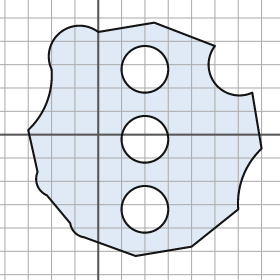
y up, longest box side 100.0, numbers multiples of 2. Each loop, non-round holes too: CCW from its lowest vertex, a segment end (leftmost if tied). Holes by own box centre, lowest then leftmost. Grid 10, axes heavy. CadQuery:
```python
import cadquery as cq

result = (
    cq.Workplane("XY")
    .moveTo(16.0, -52.0)
    .lineTo(40.0, -48.0)
    .lineTo(60.0, -32.0)
    .threePointArc((62.0, -18.0), (70.0, -6.0))
    .lineTo(66.0, 18.0)
    .threePointArc((50.0, 22.0), (50.0, 38.0))
    .lineTo(24.0, 48.0)
    .lineTo(0.0, 44.0)
    .threePointArc((-16.0, 44.0), (-20.0, 28.0))
    .threePointArc((-22.0, 14.0), (-30.0, 2.0))
    .lineTo(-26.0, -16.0)
    .threePointArc((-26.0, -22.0), (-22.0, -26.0))
    .lineTo(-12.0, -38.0)
    .threePointArc((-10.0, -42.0), (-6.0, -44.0))
    .close()
    .moveTo(20.0, -32.0)
    .circle(10.0)
    .moveTo(20.0, -2.0)
    .circle(10.0)
    .moveTo(20.0, 28.0)
    .circle(10.0)
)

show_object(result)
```